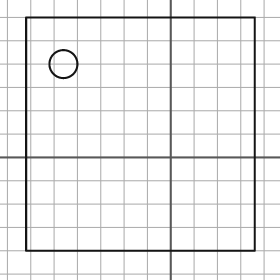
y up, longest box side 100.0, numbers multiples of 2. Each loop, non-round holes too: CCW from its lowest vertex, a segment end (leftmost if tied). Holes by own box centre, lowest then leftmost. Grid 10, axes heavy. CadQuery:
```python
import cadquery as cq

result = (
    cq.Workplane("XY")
    .moveTo(-62.0, -40.0)
    .lineTo(36.0, -40.0)
    .lineTo(36.0, 60.0)
    .lineTo(-62.0, 60.0)
    .close()
    .moveTo(-46.0, 40.0)
    .circle(6.0)
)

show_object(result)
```